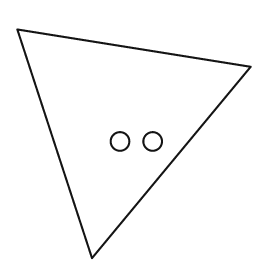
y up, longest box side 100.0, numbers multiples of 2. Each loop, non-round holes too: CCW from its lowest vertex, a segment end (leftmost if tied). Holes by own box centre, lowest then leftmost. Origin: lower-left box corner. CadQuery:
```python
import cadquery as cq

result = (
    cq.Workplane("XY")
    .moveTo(32.0, 0.0)
    .lineTo(100.0, 82.0)
    .lineTo(0.0, 98.0)
    .close()
    .moveTo(44.0, 50.0)
    .circle(4.0)
    .moveTo(58.0, 50.0)
    .circle(4.0)
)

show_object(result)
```